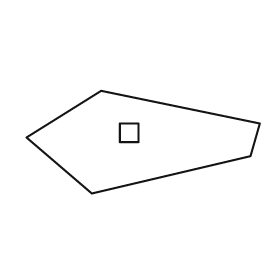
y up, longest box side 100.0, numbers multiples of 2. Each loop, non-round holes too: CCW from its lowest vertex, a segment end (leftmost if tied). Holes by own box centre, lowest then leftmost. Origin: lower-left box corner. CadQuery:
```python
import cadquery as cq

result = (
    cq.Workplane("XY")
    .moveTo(28.0, 0.0)
    .lineTo(96.0, 16.0)
    .lineTo(100.0, 30.0)
    .lineTo(32.0, 44.0)
    .lineTo(0.0, 24.0)
    .close()
    .moveTo(40.0, 22.0)
    .lineTo(48.0, 22.0)
    .lineTo(48.0, 30.0)
    .lineTo(40.0, 30.0)
    .close()
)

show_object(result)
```